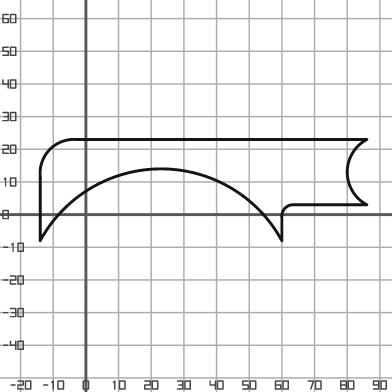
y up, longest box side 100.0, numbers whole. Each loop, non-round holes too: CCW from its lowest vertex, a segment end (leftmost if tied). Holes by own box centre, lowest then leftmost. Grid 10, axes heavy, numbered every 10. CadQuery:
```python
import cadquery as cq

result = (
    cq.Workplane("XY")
    .moveTo(-14.0, -8.0)
    .threePointArc((23.0, 14.0), (60.0, -8.0))
    .lineTo(60.0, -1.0)
    .threePointArc((61.0, 2.0), (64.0, 3.0))
    .lineTo(86.0, 3.0)
    .threePointArc((80.0, 13.0), (86.0, 23.0))
    .lineTo(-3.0, 23.0)
    .threePointArc((-11.0, 20.0), (-14.0, 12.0))
    .close()
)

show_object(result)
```